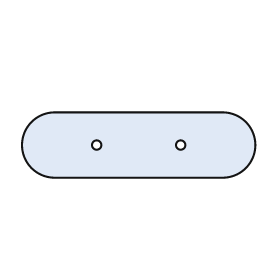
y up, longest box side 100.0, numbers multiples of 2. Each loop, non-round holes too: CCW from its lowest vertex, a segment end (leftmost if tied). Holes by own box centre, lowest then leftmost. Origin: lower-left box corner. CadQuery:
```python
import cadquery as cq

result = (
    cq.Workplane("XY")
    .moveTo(14.0, 0.0)
    .lineTo(86.0, 0.0)
    .threePointArc((100.0, 14.0), (86.0, 28.0))
    .lineTo(14.0, 28.0)
    .threePointArc((0.0, 14.0), (14.0, 0.0))
    .close()
    .moveTo(32.0, 14.0)
    .circle(2.0)
    .moveTo(68.0, 14.0)
    .circle(2.0)
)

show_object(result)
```